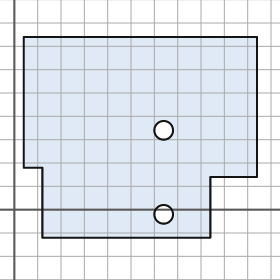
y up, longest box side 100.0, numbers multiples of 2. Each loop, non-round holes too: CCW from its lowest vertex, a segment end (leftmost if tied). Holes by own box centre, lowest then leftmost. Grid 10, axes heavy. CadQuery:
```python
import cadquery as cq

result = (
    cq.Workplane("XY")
    .moveTo(12.0, -12.0)
    .lineTo(84.0, -12.0)
    .lineTo(84.0, 14.0)
    .lineTo(104.0, 14.0)
    .lineTo(104.0, 74.0)
    .lineTo(4.0, 74.0)
    .lineTo(4.0, 18.0)
    .lineTo(12.0, 18.0)
    .close()
    .moveTo(64.0, -2.0)
    .circle(4.0)
    .moveTo(64.0, 34.0)
    .circle(4.0)
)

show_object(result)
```